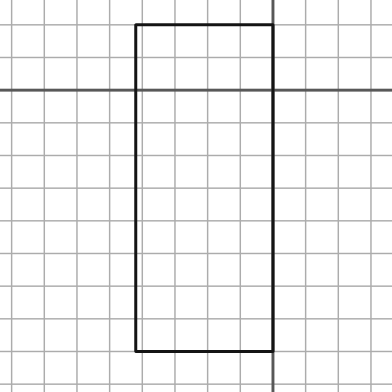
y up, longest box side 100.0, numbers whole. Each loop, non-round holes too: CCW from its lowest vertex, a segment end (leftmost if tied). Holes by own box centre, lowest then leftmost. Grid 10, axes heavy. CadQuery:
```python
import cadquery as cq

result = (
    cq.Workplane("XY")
    .moveTo(-42.0, -80.0)
    .lineTo(0.0, -80.0)
    .lineTo(0.0, 20.0)
    .lineTo(-42.0, 20.0)
    .close()
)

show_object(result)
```